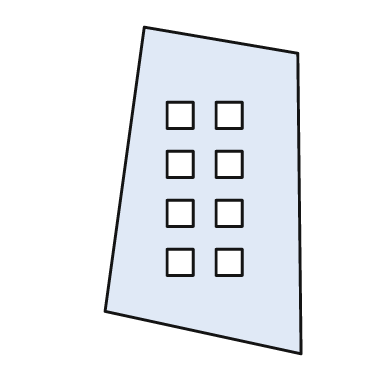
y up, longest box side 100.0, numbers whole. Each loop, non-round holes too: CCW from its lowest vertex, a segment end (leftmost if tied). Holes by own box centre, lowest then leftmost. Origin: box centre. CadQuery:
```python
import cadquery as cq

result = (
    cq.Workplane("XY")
    .moveTo(30.0, -50.0)
    .lineTo(29.0, 42.0)
    .lineTo(-18.0, 50.0)
    .lineTo(-30.0, -37.0)
    .close()
    .moveTo(-11.0, -26.0)
    .lineTo(-3.0, -26.0)
    .lineTo(-3.0, -18.0)
    .lineTo(-11.0, -18.0)
    .close()
    .moveTo(4.0, -26.0)
    .lineTo(12.0, -26.0)
    .lineTo(12.0, -18.0)
    .lineTo(4.0, -18.0)
    .close()
    .moveTo(-11.0, -11.0)
    .lineTo(-3.0, -11.0)
    .lineTo(-3.0, -3.0)
    .lineTo(-11.0, -3.0)
    .close()
    .moveTo(4.0, -11.0)
    .lineTo(12.0, -11.0)
    .lineTo(12.0, -3.0)
    .lineTo(4.0, -3.0)
    .close()
    .moveTo(-11.0, 4.0)
    .lineTo(-3.0, 4.0)
    .lineTo(-3.0, 12.0)
    .lineTo(-11.0, 12.0)
    .close()
    .moveTo(4.0, 4.0)
    .lineTo(12.0, 4.0)
    .lineTo(12.0, 12.0)
    .lineTo(4.0, 12.0)
    .close()
    .moveTo(-11.0, 19.0)
    .lineTo(-3.0, 19.0)
    .lineTo(-3.0, 27.0)
    .lineTo(-11.0, 27.0)
    .close()
    .moveTo(4.0, 19.0)
    .lineTo(12.0, 19.0)
    .lineTo(12.0, 27.0)
    .lineTo(4.0, 27.0)
    .close()
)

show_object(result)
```